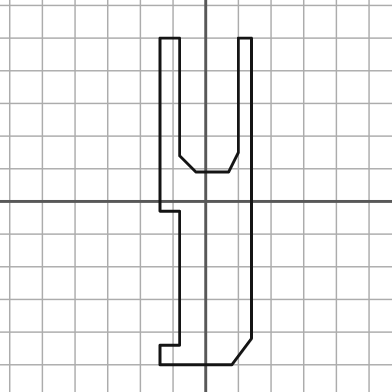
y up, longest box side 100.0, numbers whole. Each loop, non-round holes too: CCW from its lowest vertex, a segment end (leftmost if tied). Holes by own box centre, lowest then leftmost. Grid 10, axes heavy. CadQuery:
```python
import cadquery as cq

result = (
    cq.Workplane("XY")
    .moveTo(-14.0, -50.0)
    .lineTo(8.0, -50.0)
    .lineTo(14.0, -42.0)
    .lineTo(14.0, 50.0)
    .lineTo(10.0, 50.0)
    .lineTo(10.0, 15.0)
    .lineTo(7.0, 9.0)
    .lineTo(-3.0, 9.0)
    .lineTo(-8.0, 14.0)
    .lineTo(-8.0, 50.0)
    .lineTo(-14.0, 50.0)
    .lineTo(-14.0, -3.0)
    .lineTo(-8.0, -3.0)
    .lineTo(-8.0, -44.0)
    .lineTo(-14.0, -44.0)
    .close()
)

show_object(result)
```